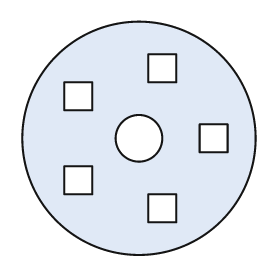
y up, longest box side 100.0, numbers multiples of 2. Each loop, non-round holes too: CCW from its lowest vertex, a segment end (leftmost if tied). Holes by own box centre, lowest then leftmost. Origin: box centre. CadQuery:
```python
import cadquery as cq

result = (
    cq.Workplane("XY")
    .moveTo(0.0, 0.0)
    .circle(50.0)
    .moveTo(4.0, -36.0)
    .lineTo(16.0, -36.0)
    .lineTo(16.0, -24.0)
    .lineTo(4.0, -24.0)
    .close()
    .moveTo(-32.0, -24.0)
    .lineTo(-20.0, -24.0)
    .lineTo(-20.0, -12.0)
    .lineTo(-32.0, -12.0)
    .close()
    .moveTo(0.0, 0.0)
    .circle(10.0)
    .moveTo(26.0, -6.0)
    .lineTo(38.0, -6.0)
    .lineTo(38.0, 6.0)
    .lineTo(26.0, 6.0)
    .close()
    .moveTo(-32.0, 12.0)
    .lineTo(-20.0, 12.0)
    .lineTo(-20.0, 24.0)
    .lineTo(-32.0, 24.0)
    .close()
    .moveTo(4.0, 24.0)
    .lineTo(16.0, 24.0)
    .lineTo(16.0, 36.0)
    .lineTo(4.0, 36.0)
    .close()
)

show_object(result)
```